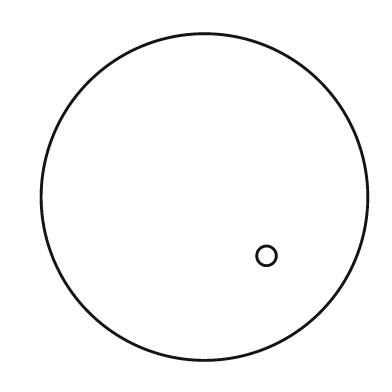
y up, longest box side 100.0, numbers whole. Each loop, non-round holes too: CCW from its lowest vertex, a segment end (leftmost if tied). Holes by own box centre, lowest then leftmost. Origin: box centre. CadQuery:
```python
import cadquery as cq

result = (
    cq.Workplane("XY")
    .moveTo(0.0, 0.0)
    .circle(50.0)
    .moveTo(19.0, -18.0)
    .circle(3.0)
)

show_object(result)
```